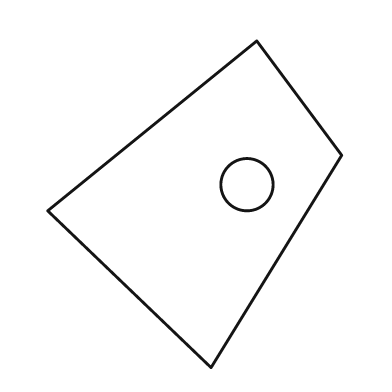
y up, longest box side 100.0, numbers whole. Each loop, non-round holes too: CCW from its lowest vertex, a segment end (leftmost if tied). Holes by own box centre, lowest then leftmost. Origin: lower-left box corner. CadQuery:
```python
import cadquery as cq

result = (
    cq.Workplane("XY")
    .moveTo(50.0, 0.0)
    .lineTo(90.0, 65.0)
    .lineTo(64.0, 100.0)
    .lineTo(0.0, 48.0)
    .close()
    .moveTo(61.0, 56.0)
    .circle(8.0)
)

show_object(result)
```